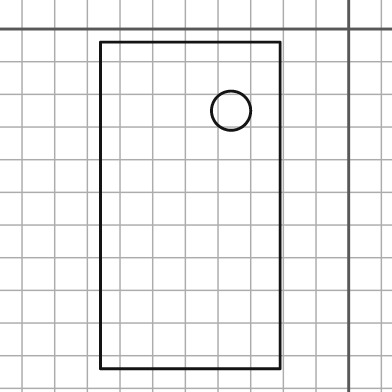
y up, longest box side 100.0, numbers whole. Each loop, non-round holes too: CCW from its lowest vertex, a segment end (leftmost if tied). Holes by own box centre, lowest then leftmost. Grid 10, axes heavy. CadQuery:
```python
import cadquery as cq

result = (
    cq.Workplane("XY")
    .moveTo(-76.0, -104.0)
    .lineTo(-21.0, -104.0)
    .lineTo(-21.0, -4.0)
    .lineTo(-76.0, -4.0)
    .close()
    .moveTo(-36.0, -25.0)
    .circle(6.0)
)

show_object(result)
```